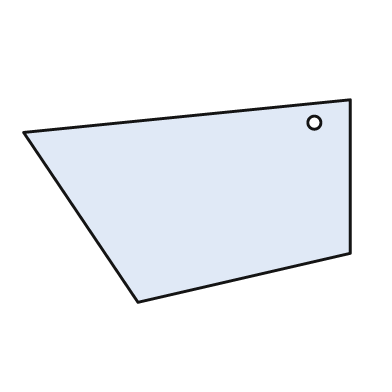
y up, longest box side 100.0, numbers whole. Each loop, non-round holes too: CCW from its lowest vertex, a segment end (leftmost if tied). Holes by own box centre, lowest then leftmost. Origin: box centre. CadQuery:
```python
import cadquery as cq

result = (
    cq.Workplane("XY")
    .moveTo(-15.0, -31.0)
    .lineTo(50.0, -16.0)
    .lineTo(50.0, 31.0)
    .lineTo(-50.0, 21.0)
    .close()
    .moveTo(39.0, 24.0)
    .circle(2.0)
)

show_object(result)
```